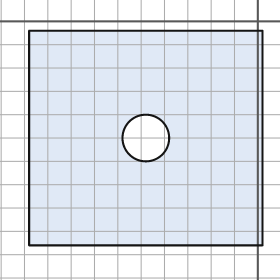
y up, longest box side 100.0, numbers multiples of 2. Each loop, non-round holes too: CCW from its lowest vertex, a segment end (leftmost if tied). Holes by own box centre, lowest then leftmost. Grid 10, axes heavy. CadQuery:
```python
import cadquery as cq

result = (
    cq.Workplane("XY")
    .moveTo(-98.0, -96.0)
    .lineTo(2.0, -96.0)
    .lineTo(2.0, -4.0)
    .lineTo(-98.0, -4.0)
    .close()
    .moveTo(-48.0, -50.0)
    .circle(10.0)
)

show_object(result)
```